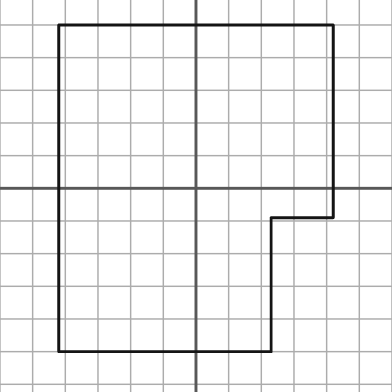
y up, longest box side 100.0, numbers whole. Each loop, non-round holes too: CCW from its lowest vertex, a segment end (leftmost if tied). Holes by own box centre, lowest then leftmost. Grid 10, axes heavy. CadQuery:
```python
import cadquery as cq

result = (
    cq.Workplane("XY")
    .moveTo(-42.0, -50.0)
    .lineTo(23.0, -50.0)
    .lineTo(23.0, -9.0)
    .lineTo(42.0, -9.0)
    .lineTo(42.0, 50.0)
    .lineTo(-42.0, 50.0)
    .close()
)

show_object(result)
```